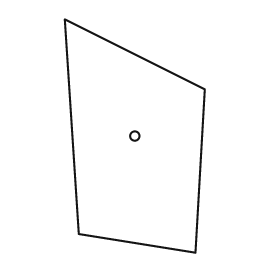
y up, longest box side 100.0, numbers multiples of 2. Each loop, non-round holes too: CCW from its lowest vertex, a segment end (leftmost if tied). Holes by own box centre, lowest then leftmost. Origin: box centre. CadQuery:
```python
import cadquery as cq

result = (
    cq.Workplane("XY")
    .moveTo(26.0, -50.0)
    .lineTo(30.0, 20.0)
    .lineTo(-30.0, 50.0)
    .lineTo(-24.0, -42.0)
    .close()
    .moveTo(0.0, 0.0)
    .circle(2.0)
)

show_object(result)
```